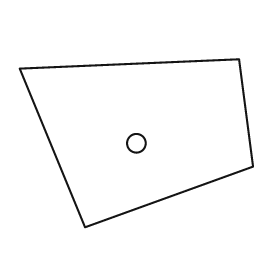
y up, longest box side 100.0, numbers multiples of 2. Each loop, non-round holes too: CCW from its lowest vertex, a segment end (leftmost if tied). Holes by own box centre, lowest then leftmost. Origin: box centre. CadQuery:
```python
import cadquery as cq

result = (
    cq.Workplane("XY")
    .moveTo(-22.0, -36.0)
    .lineTo(50.0, -10.0)
    .lineTo(44.0, 36.0)
    .lineTo(-50.0, 32.0)
    .close()
    .moveTo(0.0, 0.0)
    .circle(4.0)
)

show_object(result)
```